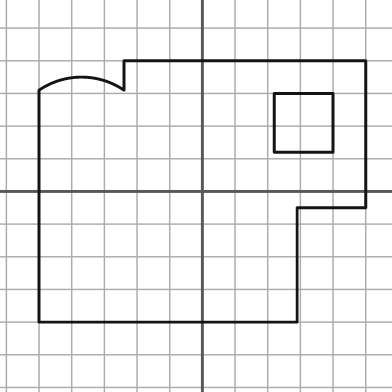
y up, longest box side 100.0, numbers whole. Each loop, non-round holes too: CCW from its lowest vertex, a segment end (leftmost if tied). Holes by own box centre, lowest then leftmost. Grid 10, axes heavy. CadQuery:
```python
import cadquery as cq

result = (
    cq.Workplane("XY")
    .moveTo(-50.0, -40.0)
    .lineTo(29.0, -40.0)
    .lineTo(29.0, -5.0)
    .lineTo(50.0, -5.0)
    .lineTo(50.0, 40.0)
    .lineTo(-24.0, 40.0)
    .lineTo(-24.0, 31.0)
    .threePointArc((-37.0, 35.0), (-50.0, 31.0))
    .close()
    .moveTo(22.0, 12.0)
    .lineTo(40.0, 12.0)
    .lineTo(40.0, 30.0)
    .lineTo(22.0, 30.0)
    .close()
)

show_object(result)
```